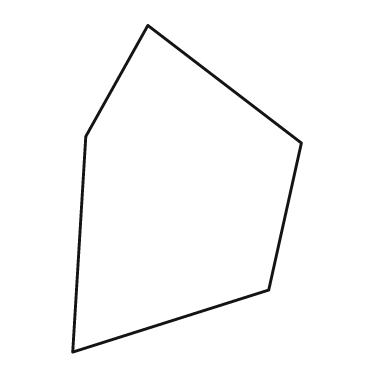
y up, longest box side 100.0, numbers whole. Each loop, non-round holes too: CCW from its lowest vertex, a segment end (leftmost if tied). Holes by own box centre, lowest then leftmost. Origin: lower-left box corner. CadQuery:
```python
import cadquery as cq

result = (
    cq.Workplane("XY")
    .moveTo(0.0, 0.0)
    .lineTo(60.0, 19.0)
    .lineTo(70.0, 64.0)
    .lineTo(23.0, 100.0)
    .lineTo(4.0, 66.0)
    .close()
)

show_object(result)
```